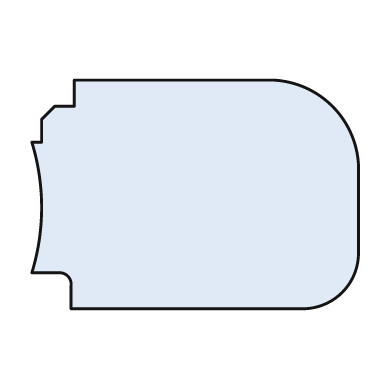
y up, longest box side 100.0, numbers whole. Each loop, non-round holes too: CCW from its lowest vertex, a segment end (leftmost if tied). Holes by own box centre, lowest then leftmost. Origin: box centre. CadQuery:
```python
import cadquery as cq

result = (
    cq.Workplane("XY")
    .moveTo(-38.0, -35.0)
    .lineTo(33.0, -35.0)
    .threePointArc((45.0, -30.0), (50.0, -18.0))
    .lineTo(50.0, 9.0)
    .threePointArc((42.0, 27.0), (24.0, 35.0))
    .lineTo(-37.0, 35.0)
    .lineTo(-37.0, 27.0)
    .lineTo(-43.0, 27.0)
    .lineTo(-47.0, 23.0)
    .lineTo(-47.0, 16.0)
    .lineTo(-50.0, 16.0)
    .threePointArc((-47.0, -4.0), (-50.0, -24.0))
    .lineTo(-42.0, -24.0)
    .threePointArc((-39.0, -25.0), (-38.0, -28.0))
    .close()
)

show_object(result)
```